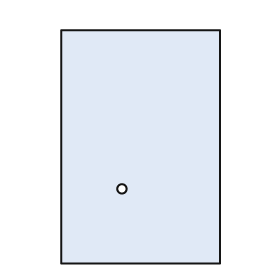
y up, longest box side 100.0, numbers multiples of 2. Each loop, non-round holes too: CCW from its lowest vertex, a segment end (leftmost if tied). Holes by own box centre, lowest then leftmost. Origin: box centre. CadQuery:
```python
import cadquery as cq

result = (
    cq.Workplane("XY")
    .moveTo(-34.0, -50.0)
    .lineTo(34.0, -50.0)
    .lineTo(34.0, 50.0)
    .lineTo(-34.0, 50.0)
    .close()
    .moveTo(-8.0, -18.0)
    .circle(2.0)
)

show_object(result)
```